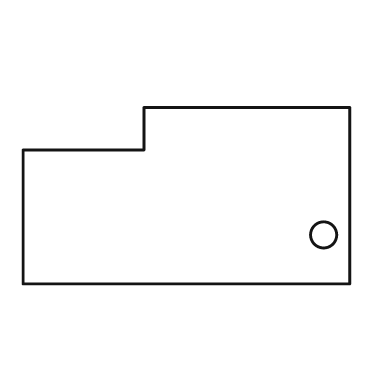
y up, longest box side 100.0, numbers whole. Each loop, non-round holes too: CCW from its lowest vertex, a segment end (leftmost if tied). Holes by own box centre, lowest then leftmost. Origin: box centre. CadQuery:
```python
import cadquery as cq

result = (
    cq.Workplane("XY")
    .moveTo(-50.0, -27.0)
    .lineTo(50.0, -27.0)
    .lineTo(50.0, 27.0)
    .lineTo(-13.0, 27.0)
    .lineTo(-13.0, 14.0)
    .lineTo(-50.0, 14.0)
    .close()
    .moveTo(42.0, -12.0)
    .circle(4.0)
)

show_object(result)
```